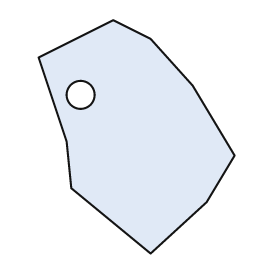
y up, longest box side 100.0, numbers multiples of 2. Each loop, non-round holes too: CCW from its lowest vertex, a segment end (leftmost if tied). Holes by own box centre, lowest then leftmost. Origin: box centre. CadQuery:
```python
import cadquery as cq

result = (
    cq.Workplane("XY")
    .moveTo(6.0, -50.0)
    .lineTo(30.0, -28.0)
    .lineTo(42.0, -8.0)
    .lineTo(24.0, 22.0)
    .lineTo(6.0, 42.0)
    .lineTo(-10.0, 50.0)
    .lineTo(-42.0, 34.0)
    .lineTo(-30.0, -2.0)
    .lineTo(-28.0, -22.0)
    .close()
    .moveTo(-24.0, 18.0)
    .circle(6.0)
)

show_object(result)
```